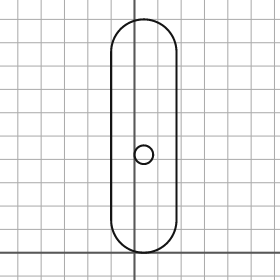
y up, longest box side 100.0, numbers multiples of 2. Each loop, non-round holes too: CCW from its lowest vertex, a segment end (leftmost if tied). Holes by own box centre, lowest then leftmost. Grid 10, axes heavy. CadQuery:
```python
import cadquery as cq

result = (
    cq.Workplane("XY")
    .moveTo(-10.0, 14.0)
    .threePointArc((4.0, 0.0), (18.0, 14.0))
    .lineTo(18.0, 86.0)
    .threePointArc((4.0, 100.0), (-10.0, 86.0))
    .close()
    .moveTo(4.0, 42.0)
    .circle(4.0)
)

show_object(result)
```